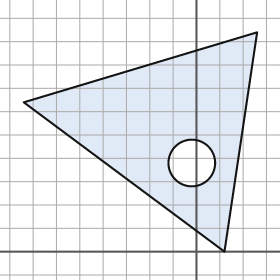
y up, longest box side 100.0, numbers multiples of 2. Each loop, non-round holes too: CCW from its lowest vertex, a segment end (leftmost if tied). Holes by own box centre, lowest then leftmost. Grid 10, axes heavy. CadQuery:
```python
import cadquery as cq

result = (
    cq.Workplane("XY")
    .moveTo(12.0, 0.0)
    .lineTo(26.0, 94.0)
    .lineTo(-74.0, 64.0)
    .close()
    .moveTo(-2.0, 38.0)
    .circle(10.0)
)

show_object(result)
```